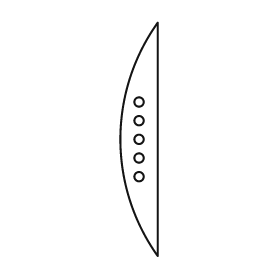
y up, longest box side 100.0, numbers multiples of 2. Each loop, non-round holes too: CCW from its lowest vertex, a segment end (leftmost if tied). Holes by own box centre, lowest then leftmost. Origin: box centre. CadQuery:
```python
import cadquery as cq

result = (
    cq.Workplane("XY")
    .moveTo(8.0, -50.0)
    .lineTo(8.0, 50.0)
    .threePointArc((-8.0, 0.0), (8.0, -50.0))
    .close()
    .moveTo(0.0, -16.0)
    .circle(2.0)
    .moveTo(0.0, -8.0)
    .circle(2.0)
    .moveTo(0.0, 0.0)
    .circle(2.0)
    .moveTo(0.0, 8.0)
    .circle(2.0)
    .moveTo(0.0, 16.0)
    .circle(2.0)
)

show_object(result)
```